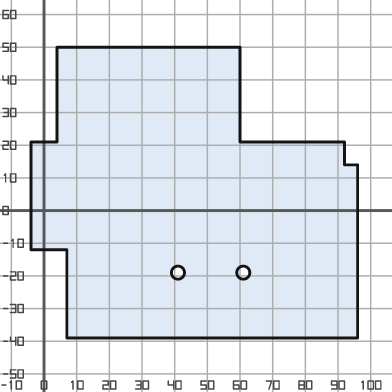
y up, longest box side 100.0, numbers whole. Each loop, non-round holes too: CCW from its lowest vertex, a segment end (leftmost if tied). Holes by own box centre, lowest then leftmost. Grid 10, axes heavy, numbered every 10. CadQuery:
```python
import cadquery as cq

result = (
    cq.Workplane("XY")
    .moveTo(7.0, -39.0)
    .lineTo(96.0, -39.0)
    .lineTo(96.0, 14.0)
    .lineTo(92.0, 14.0)
    .lineTo(92.0, 21.0)
    .lineTo(60.0, 21.0)
    .lineTo(60.0, 50.0)
    .lineTo(4.0, 50.0)
    .lineTo(4.0, 21.0)
    .lineTo(-4.0, 21.0)
    .lineTo(-4.0, -12.0)
    .lineTo(7.0, -12.0)
    .close()
    .moveTo(41.0, -19.0)
    .circle(2.0)
    .moveTo(61.0, -19.0)
    .circle(2.0)
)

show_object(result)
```